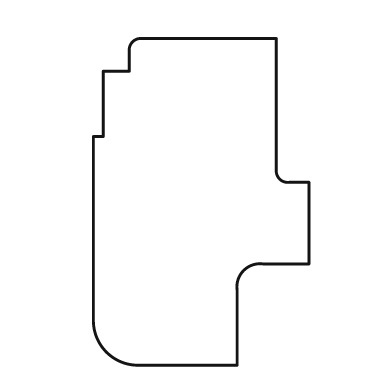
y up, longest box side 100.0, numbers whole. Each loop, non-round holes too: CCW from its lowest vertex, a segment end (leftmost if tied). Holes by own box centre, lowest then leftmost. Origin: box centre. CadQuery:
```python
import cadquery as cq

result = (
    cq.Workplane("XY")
    .moveTo(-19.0, -50.0)
    .lineTo(11.0, -50.0)
    .lineTo(11.0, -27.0)
    .threePointArc((13.0, -21.0), (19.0, -19.0))
    .lineTo(33.0, -19.0)
    .lineTo(33.0, 6.0)
    .lineTo(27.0, 6.0)
    .threePointArc((24.0, 7.0), (23.0, 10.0))
    .lineTo(23.0, 50.0)
    .lineTo(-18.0, 50.0)
    .threePointArc((-21.0, 49.0), (-22.0, 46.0))
    .lineTo(-22.0, 40.0)
    .lineTo(-30.0, 40.0)
    .lineTo(-30.0, 20.0)
    .lineTo(-33.0, 20.0)
    .lineTo(-33.0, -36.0)
    .threePointArc((-29.0, -46.0), (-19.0, -50.0))
    .close()
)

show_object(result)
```